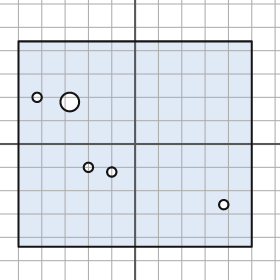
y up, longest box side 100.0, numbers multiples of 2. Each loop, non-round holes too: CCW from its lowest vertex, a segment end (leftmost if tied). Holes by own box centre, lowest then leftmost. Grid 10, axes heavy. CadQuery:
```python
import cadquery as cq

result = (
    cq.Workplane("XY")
    .moveTo(-50.0, -44.0)
    .lineTo(50.0, -44.0)
    .lineTo(50.0, 44.0)
    .lineTo(-50.0, 44.0)
    .close()
    .moveTo(38.0, -26.0)
    .circle(2.0)
    .moveTo(-10.0, -12.0)
    .circle(2.0)
    .moveTo(-20.0, -10.0)
    .circle(2.0)
    .moveTo(-28.0, 18.0)
    .circle(4.0)
    .moveTo(-42.0, 20.0)
    .circle(2.0)
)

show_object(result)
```